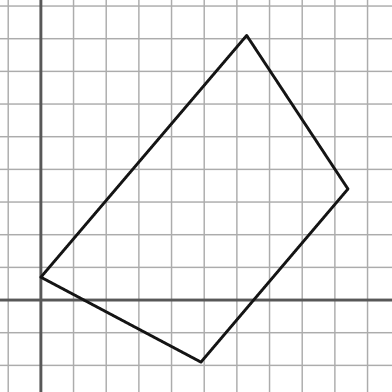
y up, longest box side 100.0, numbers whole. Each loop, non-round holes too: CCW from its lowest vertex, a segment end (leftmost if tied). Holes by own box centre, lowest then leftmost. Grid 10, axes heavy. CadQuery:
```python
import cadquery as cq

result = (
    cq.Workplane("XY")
    .moveTo(49.0, -19.0)
    .lineTo(94.0, 34.0)
    .lineTo(63.0, 81.0)
    .lineTo(0.0, 7.0)
    .close()
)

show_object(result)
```